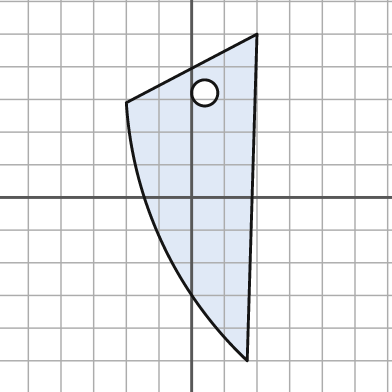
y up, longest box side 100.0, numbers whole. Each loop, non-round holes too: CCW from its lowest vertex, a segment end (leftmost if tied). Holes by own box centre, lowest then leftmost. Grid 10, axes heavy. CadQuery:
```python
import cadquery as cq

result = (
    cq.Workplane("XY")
    .moveTo(17.0, -50.0)
    .lineTo(20.0, 50.0)
    .lineTo(-20.0, 29.0)
    .threePointArc((-9.0, -14.0), (17.0, -50.0))
    .close()
    .moveTo(4.0, 32.0)
    .circle(4.0)
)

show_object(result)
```